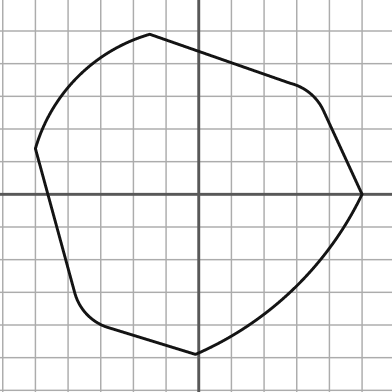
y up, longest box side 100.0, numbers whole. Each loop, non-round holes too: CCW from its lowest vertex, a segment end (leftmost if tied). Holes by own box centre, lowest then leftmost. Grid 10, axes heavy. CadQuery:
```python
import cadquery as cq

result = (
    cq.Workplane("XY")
    .moveTo(-1.0, -49.0)
    .threePointArc((29.0, -29.0), (50.0, 0.0))
    .lineTo(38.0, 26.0)
    .threePointArc((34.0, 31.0), (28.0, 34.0))
    .lineTo(-15.0, 49.0)
    .threePointArc((-37.0, 36.0), (-50.0, 14.0))
    .lineTo(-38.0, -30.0)
    .threePointArc((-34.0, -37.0), (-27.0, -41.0))
    .close()
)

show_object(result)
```